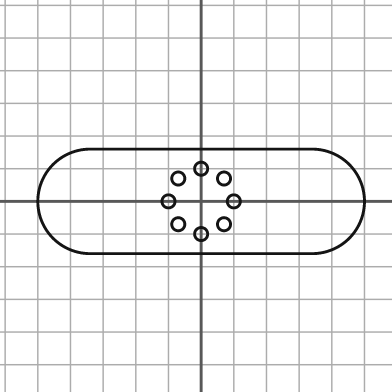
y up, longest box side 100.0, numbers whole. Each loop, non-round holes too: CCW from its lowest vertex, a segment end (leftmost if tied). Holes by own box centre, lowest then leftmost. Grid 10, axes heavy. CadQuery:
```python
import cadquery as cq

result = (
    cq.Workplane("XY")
    .moveTo(-34.0, -16.0)
    .lineTo(34.0, -16.0)
    .threePointArc((50.0, 0.0), (34.0, 16.0))
    .lineTo(-34.0, 16.0)
    .threePointArc((-50.0, 0.0), (-34.0, -16.0))
    .close()
    .moveTo(0.0, -10.0)
    .circle(2.0)
    .moveTo(-7.0, -7.0)
    .circle(2.0)
    .moveTo(7.0, -7.0)
    .circle(2.0)
    .moveTo(-10.0, 0.0)
    .circle(2.0)
    .moveTo(10.0, 0.0)
    .circle(2.0)
    .moveTo(-7.0, 7.0)
    .circle(2.0)
    .moveTo(7.0, 7.0)
    .circle(2.0)
    .moveTo(0.0, 10.0)
    .circle(2.0)
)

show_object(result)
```